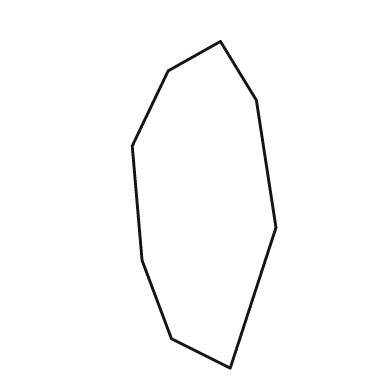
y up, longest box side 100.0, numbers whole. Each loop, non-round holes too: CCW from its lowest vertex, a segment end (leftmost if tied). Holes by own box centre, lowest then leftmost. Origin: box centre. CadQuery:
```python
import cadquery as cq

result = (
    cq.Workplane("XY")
    .moveTo(8.0, -50.0)
    .lineTo(22.0, -7.0)
    .lineTo(16.0, 32.0)
    .lineTo(5.0, 50.0)
    .lineTo(-11.0, 41.0)
    .lineTo(-22.0, 18.0)
    .lineTo(-19.0, -17.0)
    .lineTo(-10.0, -41.0)
    .close()
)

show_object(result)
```